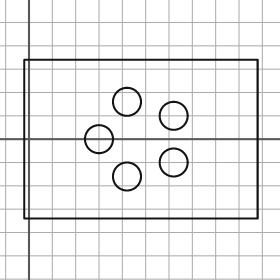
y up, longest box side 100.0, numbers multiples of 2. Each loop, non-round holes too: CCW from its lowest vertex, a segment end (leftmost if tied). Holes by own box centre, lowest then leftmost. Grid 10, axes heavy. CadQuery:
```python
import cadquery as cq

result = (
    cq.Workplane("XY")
    .moveTo(-2.0, -34.0)
    .lineTo(98.0, -34.0)
    .lineTo(98.0, 34.0)
    .lineTo(-2.0, 34.0)
    .close()
    .moveTo(42.0, -16.0)
    .circle(6.0)
    .moveTo(62.0, -10.0)
    .circle(6.0)
    .moveTo(30.0, 0.0)
    .circle(6.0)
    .moveTo(62.0, 10.0)
    .circle(6.0)
    .moveTo(42.0, 16.0)
    .circle(6.0)
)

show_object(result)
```